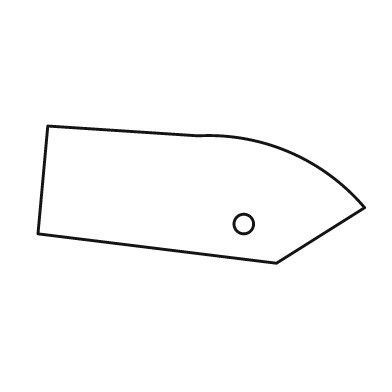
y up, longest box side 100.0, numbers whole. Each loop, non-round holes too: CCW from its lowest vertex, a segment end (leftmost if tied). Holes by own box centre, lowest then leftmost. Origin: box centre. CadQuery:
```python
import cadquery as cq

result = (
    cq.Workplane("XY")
    .moveTo(23.0, -21.0)
    .lineTo(50.0, -4.0)
    .threePointArc((27.0, 13.0), (-1.0, 18.0))
    .lineTo(-47.0, 21.0)
    .lineTo(-50.0, -12.0)
    .close()
    .moveTo(13.0, -9.0)
    .circle(3.0)
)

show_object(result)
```